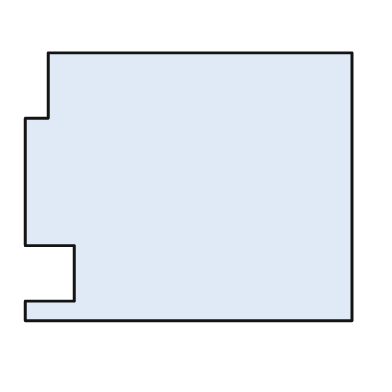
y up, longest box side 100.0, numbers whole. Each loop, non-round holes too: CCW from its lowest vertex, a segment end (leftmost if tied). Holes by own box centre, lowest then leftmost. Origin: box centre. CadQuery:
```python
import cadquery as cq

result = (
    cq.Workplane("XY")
    .moveTo(-50.0, -41.0)
    .lineTo(50.0, -41.0)
    .lineTo(50.0, 41.0)
    .lineTo(-43.0, 41.0)
    .lineTo(-43.0, 21.0)
    .lineTo(-50.0, 21.0)
    .lineTo(-50.0, -18.0)
    .lineTo(-35.0, -18.0)
    .lineTo(-35.0, -35.0)
    .lineTo(-50.0, -35.0)
    .close()
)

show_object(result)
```